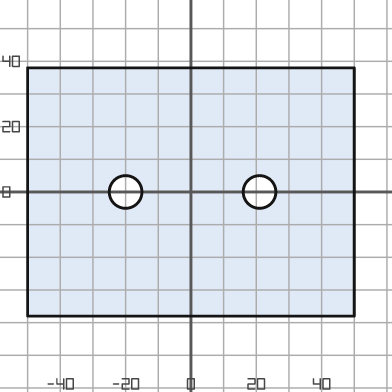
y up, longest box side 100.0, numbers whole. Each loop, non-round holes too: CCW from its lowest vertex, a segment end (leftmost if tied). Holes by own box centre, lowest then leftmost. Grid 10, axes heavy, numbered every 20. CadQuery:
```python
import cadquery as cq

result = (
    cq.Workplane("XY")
    .moveTo(-50.0, -38.0)
    .lineTo(50.0, -38.0)
    .lineTo(50.0, 38.0)
    .lineTo(-50.0, 38.0)
    .close()
    .moveTo(-20.0, 0.0)
    .circle(5.0)
    .moveTo(21.0, 0.0)
    .circle(5.0)
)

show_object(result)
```